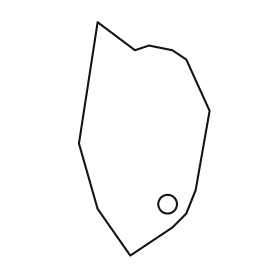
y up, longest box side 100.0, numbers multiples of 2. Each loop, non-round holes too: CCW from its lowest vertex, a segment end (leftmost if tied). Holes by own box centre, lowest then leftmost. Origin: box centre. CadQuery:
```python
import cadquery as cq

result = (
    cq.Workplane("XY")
    .moveTo(-6.0, -50.0)
    .lineTo(12.0, -38.0)
    .lineTo(18.0, -32.0)
    .lineTo(22.0, -22.0)
    .lineTo(28.0, 12.0)
    .lineTo(18.0, 34.0)
    .lineTo(12.0, 38.0)
    .lineTo(2.0, 40.0)
    .lineTo(-4.0, 38.0)
    .lineTo(-20.0, 50.0)
    .lineTo(-28.0, -2.0)
    .lineTo(-20.0, -30.0)
    .close()
    .moveTo(10.0, -28.0)
    .circle(4.0)
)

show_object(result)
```